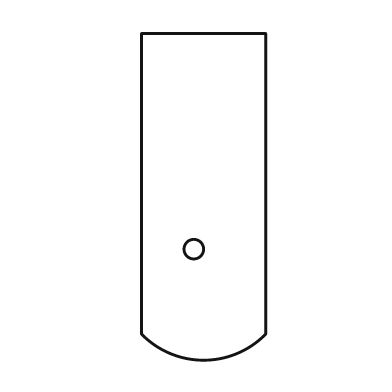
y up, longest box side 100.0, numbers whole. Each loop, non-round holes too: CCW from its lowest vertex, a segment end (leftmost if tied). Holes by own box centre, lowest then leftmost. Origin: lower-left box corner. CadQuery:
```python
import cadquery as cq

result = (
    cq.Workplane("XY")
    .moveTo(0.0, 8.0)
    .threePointArc((19.0, 0.0), (38.0, 8.0))
    .lineTo(38.0, 100.0)
    .lineTo(0.0, 100.0)
    .close()
    .moveTo(16.0, 34.0)
    .circle(3.0)
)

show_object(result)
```